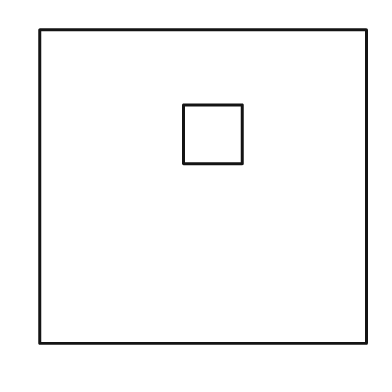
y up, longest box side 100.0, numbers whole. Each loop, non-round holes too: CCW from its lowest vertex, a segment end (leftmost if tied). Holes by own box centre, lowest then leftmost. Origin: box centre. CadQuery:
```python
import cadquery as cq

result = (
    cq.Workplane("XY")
    .moveTo(-50.0, -48.0)
    .lineTo(50.0, -48.0)
    .lineTo(50.0, 48.0)
    .lineTo(-50.0, 48.0)
    .close()
    .moveTo(-6.0, 7.0)
    .lineTo(12.0, 7.0)
    .lineTo(12.0, 25.0)
    .lineTo(-6.0, 25.0)
    .close()
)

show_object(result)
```